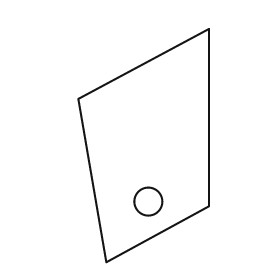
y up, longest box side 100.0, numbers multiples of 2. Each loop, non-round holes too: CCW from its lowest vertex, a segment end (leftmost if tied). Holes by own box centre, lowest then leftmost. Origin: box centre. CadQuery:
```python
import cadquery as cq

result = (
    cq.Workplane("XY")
    .moveTo(-16.0, -50.0)
    .lineTo(28.0, -26.0)
    .lineTo(28.0, 50.0)
    .lineTo(-28.0, 20.0)
    .close()
    .moveTo(2.0, -24.0)
    .circle(6.0)
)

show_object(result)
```